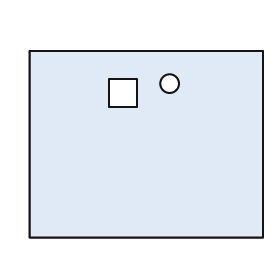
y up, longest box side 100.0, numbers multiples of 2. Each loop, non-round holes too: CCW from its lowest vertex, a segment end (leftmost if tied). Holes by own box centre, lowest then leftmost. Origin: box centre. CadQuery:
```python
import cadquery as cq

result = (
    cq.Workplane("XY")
    .moveTo(-50.0, -40.0)
    .lineTo(50.0, -40.0)
    .lineTo(50.0, 40.0)
    .lineTo(-50.0, 40.0)
    .close()
    .moveTo(-16.0, 16.0)
    .lineTo(-4.0, 16.0)
    .lineTo(-4.0, 28.0)
    .lineTo(-16.0, 28.0)
    .close()
    .moveTo(10.0, 26.0)
    .circle(4.0)
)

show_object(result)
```